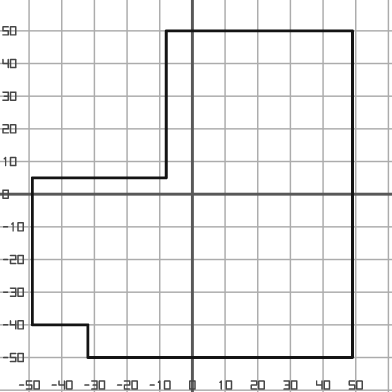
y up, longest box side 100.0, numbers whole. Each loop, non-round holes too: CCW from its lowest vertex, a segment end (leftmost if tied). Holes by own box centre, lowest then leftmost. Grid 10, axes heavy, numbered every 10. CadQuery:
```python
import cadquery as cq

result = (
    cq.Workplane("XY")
    .moveTo(-32.0, -50.0)
    .lineTo(49.0, -50.0)
    .lineTo(49.0, 50.0)
    .lineTo(-8.0, 50.0)
    .lineTo(-8.0, 5.0)
    .lineTo(-49.0, 5.0)
    .lineTo(-49.0, -40.0)
    .lineTo(-32.0, -40.0)
    .close()
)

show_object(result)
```